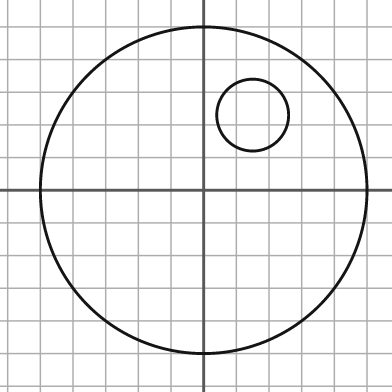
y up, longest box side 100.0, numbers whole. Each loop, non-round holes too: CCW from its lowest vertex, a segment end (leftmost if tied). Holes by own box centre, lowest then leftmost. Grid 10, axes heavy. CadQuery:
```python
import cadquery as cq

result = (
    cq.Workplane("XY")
    .moveTo(0.0, 0.0)
    .circle(50.0)
    .moveTo(15.0, 23.0)
    .circle(11.0)
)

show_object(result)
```